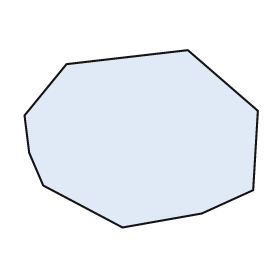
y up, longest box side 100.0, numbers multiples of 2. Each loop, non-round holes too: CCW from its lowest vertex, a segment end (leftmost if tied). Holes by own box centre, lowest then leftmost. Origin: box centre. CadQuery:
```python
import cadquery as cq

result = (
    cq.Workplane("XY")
    .moveTo(-8.0, -38.0)
    .lineTo(26.0, -32.0)
    .lineTo(48.0, -22.0)
    .lineTo(50.0, 12.0)
    .lineTo(20.0, 38.0)
    .lineTo(-32.0, 32.0)
    .lineTo(-50.0, 10.0)
    .lineTo(-48.0, -6.0)
    .lineTo(-42.0, -20.0)
    .close()
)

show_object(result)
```